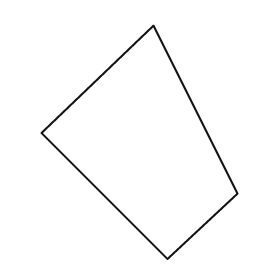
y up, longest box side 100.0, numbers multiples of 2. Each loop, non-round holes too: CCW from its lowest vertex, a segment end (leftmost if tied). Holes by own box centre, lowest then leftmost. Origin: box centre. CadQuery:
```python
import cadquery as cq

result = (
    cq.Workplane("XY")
    .moveTo(12.0, -50.0)
    .lineTo(42.0, -22.0)
    .lineTo(6.0, 50.0)
    .lineTo(-42.0, 4.0)
    .close()
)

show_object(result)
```